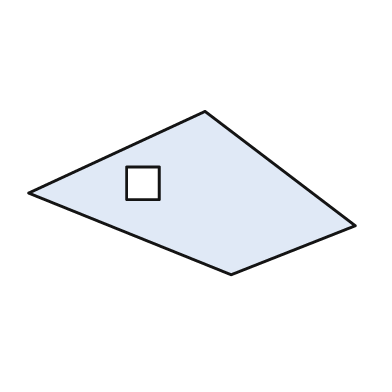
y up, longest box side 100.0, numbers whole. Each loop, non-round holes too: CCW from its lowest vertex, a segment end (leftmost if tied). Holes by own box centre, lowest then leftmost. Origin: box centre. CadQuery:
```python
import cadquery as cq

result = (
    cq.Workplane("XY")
    .moveTo(12.0, -25.0)
    .lineTo(50.0, -10.0)
    .lineTo(4.0, 25.0)
    .lineTo(-50.0, 0.0)
    .close()
    .moveTo(-20.0, -2.0)
    .lineTo(-10.0, -2.0)
    .lineTo(-10.0, 8.0)
    .lineTo(-20.0, 8.0)
    .close()
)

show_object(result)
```